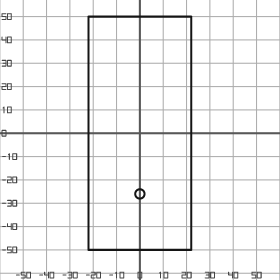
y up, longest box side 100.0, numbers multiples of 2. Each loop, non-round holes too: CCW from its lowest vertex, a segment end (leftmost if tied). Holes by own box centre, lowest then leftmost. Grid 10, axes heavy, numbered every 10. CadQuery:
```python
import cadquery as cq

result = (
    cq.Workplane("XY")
    .moveTo(-22.0, -50.0)
    .lineTo(22.0, -50.0)
    .lineTo(22.0, 50.0)
    .lineTo(-22.0, 50.0)
    .close()
    .moveTo(0.0, -26.0)
    .circle(2.0)
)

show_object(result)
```